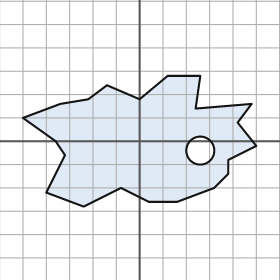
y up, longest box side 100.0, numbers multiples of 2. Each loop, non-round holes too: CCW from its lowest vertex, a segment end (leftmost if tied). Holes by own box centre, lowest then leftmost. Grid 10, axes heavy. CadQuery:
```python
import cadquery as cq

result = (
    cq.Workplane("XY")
    .moveTo(-24.0, -28.0)
    .lineTo(-8.0, -20.0)
    .lineTo(4.0, -26.0)
    .lineTo(16.0, -26.0)
    .lineTo(32.0, -20.0)
    .lineTo(38.0, -14.0)
    .lineTo(38.0, -8.0)
    .lineTo(50.0, -2.0)
    .lineTo(42.0, 8.0)
    .lineTo(48.0, 16.0)
    .lineTo(24.0, 14.0)
    .lineTo(26.0, 28.0)
    .lineTo(12.0, 28.0)
    .lineTo(0.0, 18.0)
    .lineTo(-14.0, 24.0)
    .lineTo(-22.0, 18.0)
    .lineTo(-34.0, 16.0)
    .lineTo(-50.0, 10.0)
    .lineTo(-36.0, 0.0)
    .lineTo(-32.0, -6.0)
    .lineTo(-40.0, -22.0)
    .close()
    .moveTo(26.0, -4.0)
    .circle(6.0)
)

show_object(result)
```